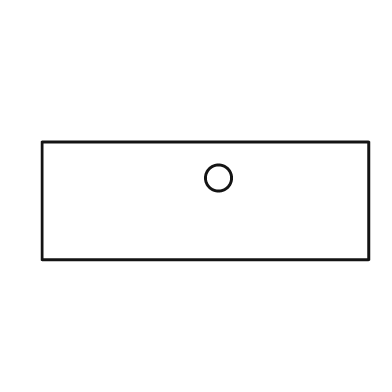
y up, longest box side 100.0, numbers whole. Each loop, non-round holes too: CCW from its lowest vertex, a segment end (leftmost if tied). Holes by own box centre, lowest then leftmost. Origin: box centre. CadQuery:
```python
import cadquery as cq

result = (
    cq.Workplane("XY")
    .moveTo(-50.0, -18.0)
    .lineTo(50.0, -18.0)
    .lineTo(50.0, 18.0)
    .lineTo(-50.0, 18.0)
    .close()
    .moveTo(4.0, 7.0)
    .circle(4.0)
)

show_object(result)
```